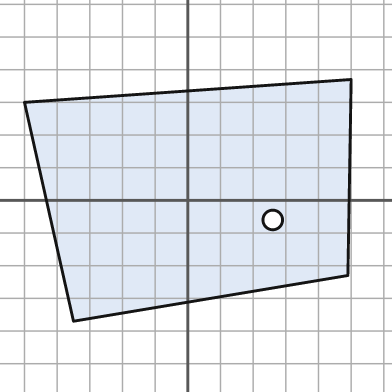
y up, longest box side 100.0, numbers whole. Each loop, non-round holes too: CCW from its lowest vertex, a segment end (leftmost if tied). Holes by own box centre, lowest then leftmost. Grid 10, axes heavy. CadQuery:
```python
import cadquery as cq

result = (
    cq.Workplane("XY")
    .moveTo(-35.0, -37.0)
    .lineTo(49.0, -23.0)
    .lineTo(50.0, 37.0)
    .lineTo(-50.0, 30.0)
    .close()
    .moveTo(26.0, -6.0)
    .circle(3.0)
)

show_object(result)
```